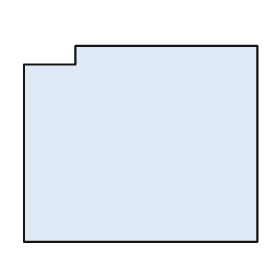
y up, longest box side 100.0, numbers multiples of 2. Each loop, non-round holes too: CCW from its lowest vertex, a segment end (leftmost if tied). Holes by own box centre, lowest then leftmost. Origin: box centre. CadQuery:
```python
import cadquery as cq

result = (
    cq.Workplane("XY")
    .moveTo(-50.0, -42.0)
    .lineTo(50.0, -42.0)
    .lineTo(50.0, 42.0)
    .lineTo(-28.0, 42.0)
    .lineTo(-28.0, 34.0)
    .lineTo(-50.0, 34.0)
    .close()
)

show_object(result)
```